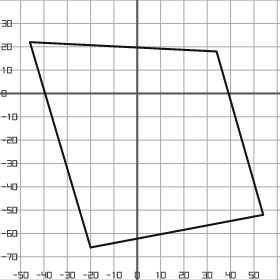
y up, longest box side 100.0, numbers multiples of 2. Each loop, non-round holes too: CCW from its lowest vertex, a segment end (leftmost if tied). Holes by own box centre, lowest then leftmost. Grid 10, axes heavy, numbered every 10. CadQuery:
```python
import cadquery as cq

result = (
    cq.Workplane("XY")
    .moveTo(-20.0, -66.0)
    .lineTo(54.0, -52.0)
    .lineTo(34.0, 18.0)
    .lineTo(-46.0, 22.0)
    .close()
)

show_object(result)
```